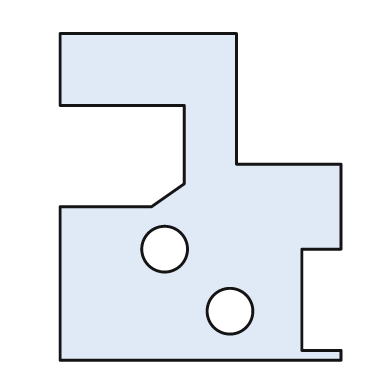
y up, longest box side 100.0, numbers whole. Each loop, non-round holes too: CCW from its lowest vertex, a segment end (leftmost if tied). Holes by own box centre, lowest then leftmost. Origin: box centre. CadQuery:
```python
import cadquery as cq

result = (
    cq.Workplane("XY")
    .moveTo(-43.0, -50.0)
    .lineTo(43.0, -50.0)
    .lineTo(43.0, -47.0)
    .lineTo(31.0, -47.0)
    .lineTo(31.0, -16.0)
    .lineTo(43.0, -16.0)
    .lineTo(43.0, 10.0)
    .lineTo(11.0, 10.0)
    .lineTo(11.0, 50.0)
    .lineTo(-43.0, 50.0)
    .lineTo(-43.0, 28.0)
    .lineTo(-5.0, 28.0)
    .lineTo(-5.0, 4.0)
    .lineTo(-15.0, -3.0)
    .lineTo(-43.0, -3.0)
    .close()
    .moveTo(9.0, -35.0)
    .circle(7.0)
    .moveTo(-11.0, -16.0)
    .circle(7.0)
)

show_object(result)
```